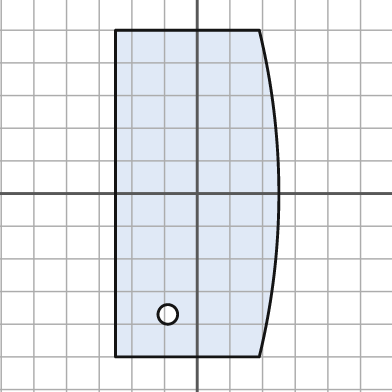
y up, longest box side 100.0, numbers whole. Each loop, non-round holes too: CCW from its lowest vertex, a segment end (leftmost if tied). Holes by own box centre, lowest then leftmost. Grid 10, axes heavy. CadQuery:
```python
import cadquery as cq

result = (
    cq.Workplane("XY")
    .moveTo(-25.0, -50.0)
    .lineTo(19.0, -50.0)
    .threePointArc((25.0, 0.0), (19.0, 50.0))
    .lineTo(-25.0, 50.0)
    .close()
    .moveTo(-9.0, -37.0)
    .circle(3.0)
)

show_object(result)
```